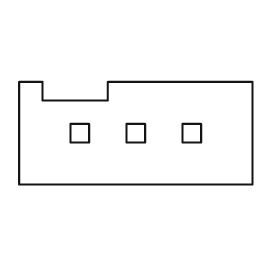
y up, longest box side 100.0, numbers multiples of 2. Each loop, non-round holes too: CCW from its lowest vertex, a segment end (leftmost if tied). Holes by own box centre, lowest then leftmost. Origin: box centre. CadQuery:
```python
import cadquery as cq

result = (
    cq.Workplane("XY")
    .moveTo(-50.0, -22.0)
    .lineTo(50.0, -22.0)
    .lineTo(50.0, 22.0)
    .lineTo(-12.0, 22.0)
    .lineTo(-12.0, 14.0)
    .lineTo(-40.0, 14.0)
    .lineTo(-40.0, 22.0)
    .lineTo(-50.0, 22.0)
    .close()
    .moveTo(-28.0, -4.0)
    .lineTo(-20.0, -4.0)
    .lineTo(-20.0, 4.0)
    .lineTo(-28.0, 4.0)
    .close()
    .moveTo(-4.0, -4.0)
    .lineTo(4.0, -4.0)
    .lineTo(4.0, 4.0)
    .lineTo(-4.0, 4.0)
    .close()
    .moveTo(20.0, -4.0)
    .lineTo(28.0, -4.0)
    .lineTo(28.0, 4.0)
    .lineTo(20.0, 4.0)
    .close()
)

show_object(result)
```